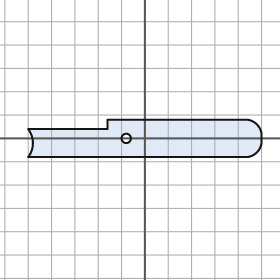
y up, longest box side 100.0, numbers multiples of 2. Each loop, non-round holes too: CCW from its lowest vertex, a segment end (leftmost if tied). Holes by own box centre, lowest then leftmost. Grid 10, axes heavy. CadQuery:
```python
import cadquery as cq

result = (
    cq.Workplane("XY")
    .moveTo(-50.0, -8.0)
    .lineTo(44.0, -8.0)
    .threePointArc((48.0, -6.0), (50.0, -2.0))
    .lineTo(50.0, 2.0)
    .threePointArc((48.0, 6.0), (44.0, 8.0))
    .lineTo(-16.0, 8.0)
    .lineTo(-16.0, 4.0)
    .lineTo(-50.0, 4.0)
    .threePointArc((-48.0, -2.0), (-50.0, -8.0))
    .close()
    .moveTo(-8.0, 0.0)
    .circle(2.0)
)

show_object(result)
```